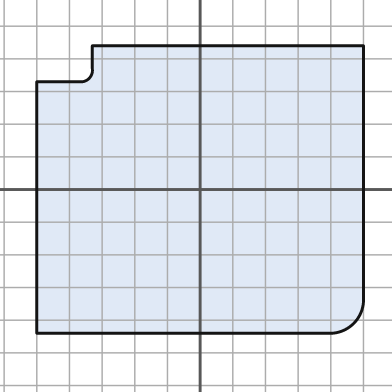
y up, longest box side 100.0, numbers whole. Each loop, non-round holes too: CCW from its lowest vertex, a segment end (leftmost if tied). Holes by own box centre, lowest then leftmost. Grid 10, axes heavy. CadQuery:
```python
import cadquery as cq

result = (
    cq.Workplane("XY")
    .moveTo(-50.0, -44.0)
    .lineTo(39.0, -44.0)
    .threePointArc((47.0, -41.0), (50.0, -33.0))
    .lineTo(50.0, 44.0)
    .lineTo(-33.0, 44.0)
    .lineTo(-33.0, 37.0)
    .threePointArc((-34.0, 34.0), (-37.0, 33.0))
    .lineTo(-50.0, 33.0)
    .close()
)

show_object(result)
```